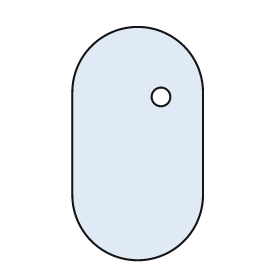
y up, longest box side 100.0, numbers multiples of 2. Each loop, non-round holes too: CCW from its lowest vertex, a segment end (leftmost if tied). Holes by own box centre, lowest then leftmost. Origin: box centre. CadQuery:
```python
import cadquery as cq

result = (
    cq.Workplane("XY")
    .moveTo(-28.0, -22.0)
    .threePointArc((0.0, -50.0), (28.0, -22.0))
    .lineTo(28.0, 22.0)
    .threePointArc((0.0, 50.0), (-28.0, 22.0))
    .close()
    .moveTo(10.0, 20.0)
    .circle(4.0)
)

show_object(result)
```